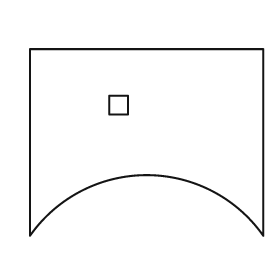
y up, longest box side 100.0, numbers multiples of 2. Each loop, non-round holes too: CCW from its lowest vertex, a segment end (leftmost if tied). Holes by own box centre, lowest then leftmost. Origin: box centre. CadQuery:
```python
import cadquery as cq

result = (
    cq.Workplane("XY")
    .moveTo(-50.0, -40.0)
    .threePointArc((0.0, -14.0), (50.0, -40.0))
    .lineTo(50.0, 40.0)
    .lineTo(-50.0, 40.0)
    .close()
    .moveTo(-16.0, 12.0)
    .lineTo(-8.0, 12.0)
    .lineTo(-8.0, 20.0)
    .lineTo(-16.0, 20.0)
    .close()
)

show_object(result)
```